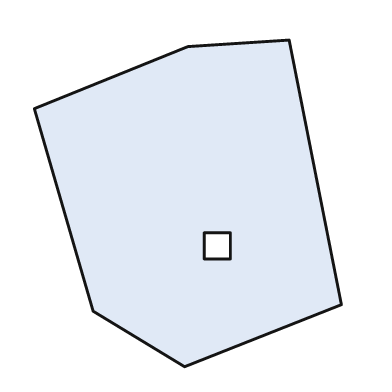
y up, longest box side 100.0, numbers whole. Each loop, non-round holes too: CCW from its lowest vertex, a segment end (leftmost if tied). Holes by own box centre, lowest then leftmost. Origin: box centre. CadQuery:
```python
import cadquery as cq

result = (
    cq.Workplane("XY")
    .moveTo(-1.0, -50.0)
    .lineTo(47.0, -31.0)
    .lineTo(31.0, 50.0)
    .lineTo(0.0, 48.0)
    .lineTo(-47.0, 29.0)
    .lineTo(-29.0, -33.0)
    .close()
    .moveTo(5.0, -17.0)
    .lineTo(13.0, -17.0)
    .lineTo(13.0, -9.0)
    .lineTo(5.0, -9.0)
    .close()
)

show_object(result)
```